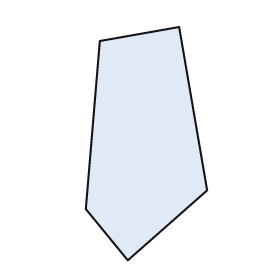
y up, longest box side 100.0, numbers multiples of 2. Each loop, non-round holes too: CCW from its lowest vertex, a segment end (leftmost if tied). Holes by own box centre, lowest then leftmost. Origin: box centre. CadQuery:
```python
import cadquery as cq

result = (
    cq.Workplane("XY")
    .moveTo(-8.0, -50.0)
    .lineTo(26.0, -20.0)
    .lineTo(14.0, 50.0)
    .lineTo(-20.0, 44.0)
    .lineTo(-26.0, -28.0)
    .close()
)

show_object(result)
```